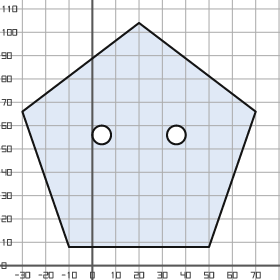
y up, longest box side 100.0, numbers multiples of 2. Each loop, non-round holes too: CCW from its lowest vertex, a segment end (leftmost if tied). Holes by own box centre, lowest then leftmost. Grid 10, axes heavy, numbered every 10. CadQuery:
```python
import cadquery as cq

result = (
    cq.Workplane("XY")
    .moveTo(-10.0, 8.0)
    .lineTo(50.0, 8.0)
    .lineTo(70.0, 66.0)
    .lineTo(20.0, 104.0)
    .lineTo(-30.0, 66.0)
    .close()
    .moveTo(4.0, 56.0)
    .circle(4.0)
    .moveTo(36.0, 56.0)
    .circle(4.0)
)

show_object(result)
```